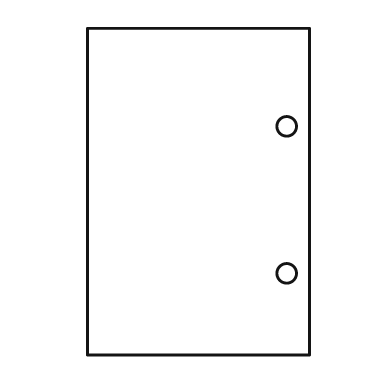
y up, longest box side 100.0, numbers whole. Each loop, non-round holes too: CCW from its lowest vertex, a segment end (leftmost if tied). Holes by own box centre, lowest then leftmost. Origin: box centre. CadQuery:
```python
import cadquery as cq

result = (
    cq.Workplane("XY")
    .moveTo(-34.0, -50.0)
    .lineTo(34.0, -50.0)
    .lineTo(34.0, 50.0)
    .lineTo(-34.0, 50.0)
    .close()
    .moveTo(27.0, -25.0)
    .circle(3.0)
    .moveTo(27.0, 20.0)
    .circle(3.0)
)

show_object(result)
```